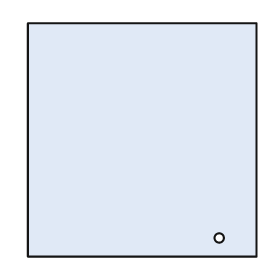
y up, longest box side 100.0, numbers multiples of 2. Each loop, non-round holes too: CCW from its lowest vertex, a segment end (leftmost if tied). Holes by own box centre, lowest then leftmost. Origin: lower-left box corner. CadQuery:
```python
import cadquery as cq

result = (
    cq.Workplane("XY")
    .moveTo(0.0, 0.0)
    .lineTo(98.0, 0.0)
    .lineTo(98.0, 100.0)
    .lineTo(0.0, 100.0)
    .close()
    .moveTo(82.0, 8.0)
    .circle(2.0)
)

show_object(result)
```